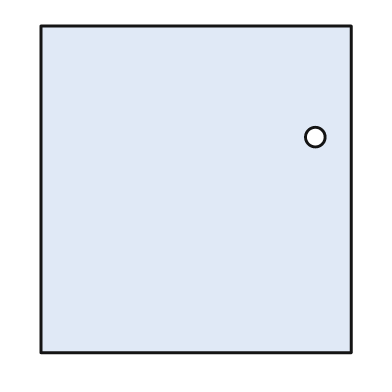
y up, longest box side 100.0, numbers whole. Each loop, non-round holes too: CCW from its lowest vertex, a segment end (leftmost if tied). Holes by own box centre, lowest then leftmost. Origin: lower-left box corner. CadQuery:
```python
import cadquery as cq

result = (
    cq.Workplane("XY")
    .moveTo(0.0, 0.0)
    .lineTo(95.0, 0.0)
    .lineTo(95.0, 100.0)
    .lineTo(0.0, 100.0)
    .close()
    .moveTo(84.0, 66.0)
    .circle(3.0)
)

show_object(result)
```